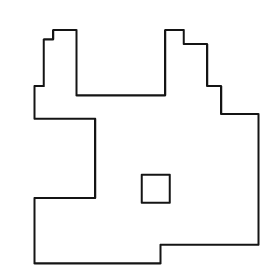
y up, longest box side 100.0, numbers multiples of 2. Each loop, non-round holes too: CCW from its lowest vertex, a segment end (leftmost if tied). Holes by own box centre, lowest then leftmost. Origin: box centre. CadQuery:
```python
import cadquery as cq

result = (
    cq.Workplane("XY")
    .moveTo(-48.0, -50.0)
    .lineTo(6.0, -50.0)
    .lineTo(6.0, -42.0)
    .lineTo(48.0, -42.0)
    .lineTo(48.0, 14.0)
    .lineTo(32.0, 14.0)
    .lineTo(32.0, 26.0)
    .lineTo(26.0, 26.0)
    .lineTo(26.0, 44.0)
    .lineTo(16.0, 44.0)
    .lineTo(16.0, 50.0)
    .lineTo(8.0, 50.0)
    .lineTo(8.0, 22.0)
    .lineTo(-30.0, 22.0)
    .lineTo(-30.0, 50.0)
    .lineTo(-40.0, 50.0)
    .lineTo(-40.0, 46.0)
    .lineTo(-44.0, 46.0)
    .lineTo(-44.0, 26.0)
    .lineTo(-48.0, 26.0)
    .lineTo(-48.0, 12.0)
    .lineTo(-22.0, 12.0)
    .lineTo(-22.0, -22.0)
    .lineTo(-48.0, -22.0)
    .close()
    .moveTo(-2.0, -24.0)
    .lineTo(10.0, -24.0)
    .lineTo(10.0, -12.0)
    .lineTo(-2.0, -12.0)
    .close()
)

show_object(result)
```